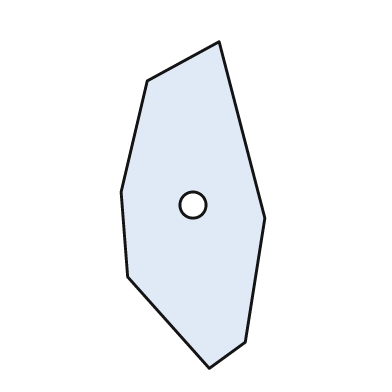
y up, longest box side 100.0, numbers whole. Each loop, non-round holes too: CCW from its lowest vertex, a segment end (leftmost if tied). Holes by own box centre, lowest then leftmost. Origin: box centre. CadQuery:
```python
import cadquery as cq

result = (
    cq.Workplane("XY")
    .moveTo(5.0, -50.0)
    .lineTo(16.0, -42.0)
    .lineTo(22.0, -4.0)
    .lineTo(8.0, 50.0)
    .lineTo(-14.0, 38.0)
    .lineTo(-22.0, 4.0)
    .lineTo(-20.0, -22.0)
    .close()
    .moveTo(0.0, 0.0)
    .circle(4.0)
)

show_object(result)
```